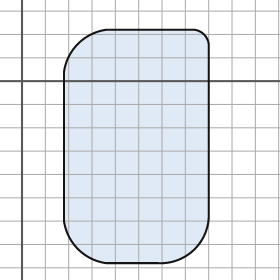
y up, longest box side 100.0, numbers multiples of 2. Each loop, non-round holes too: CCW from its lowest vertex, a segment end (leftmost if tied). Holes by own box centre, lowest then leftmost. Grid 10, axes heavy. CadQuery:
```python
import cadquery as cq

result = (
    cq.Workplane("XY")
    .moveTo(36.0, -78.0)
    .lineTo(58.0, -78.0)
    .threePointArc((74.0, -72.0), (80.0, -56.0))
    .lineTo(80.0, 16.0)
    .threePointArc((78.0, 20.0), (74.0, 22.0))
    .lineTo(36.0, 22.0)
    .threePointArc((24.0, 16.0), (18.0, 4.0))
    .lineTo(18.0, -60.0)
    .threePointArc((24.0, -72.0), (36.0, -78.0))
    .close()
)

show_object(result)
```